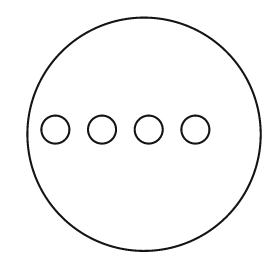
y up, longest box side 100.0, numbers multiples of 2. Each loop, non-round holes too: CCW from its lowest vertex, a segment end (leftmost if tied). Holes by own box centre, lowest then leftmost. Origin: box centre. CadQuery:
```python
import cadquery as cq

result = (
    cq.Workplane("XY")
    .moveTo(0.0, 0.0)
    .circle(50.0)
    .moveTo(-38.0, 2.0)
    .circle(6.0)
    .moveTo(-18.0, 2.0)
    .circle(6.0)
    .moveTo(2.0, 2.0)
    .circle(6.0)
    .moveTo(22.0, 2.0)
    .circle(6.0)
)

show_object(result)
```